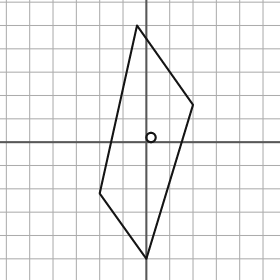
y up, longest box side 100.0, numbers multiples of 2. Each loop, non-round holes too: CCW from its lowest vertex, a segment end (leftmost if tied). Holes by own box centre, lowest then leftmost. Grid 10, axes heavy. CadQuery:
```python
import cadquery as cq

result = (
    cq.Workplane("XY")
    .moveTo(0.0, -50.0)
    .lineTo(20.0, 16.0)
    .lineTo(-4.0, 50.0)
    .lineTo(-20.0, -22.0)
    .close()
    .moveTo(2.0, 2.0)
    .circle(2.0)
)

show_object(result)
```